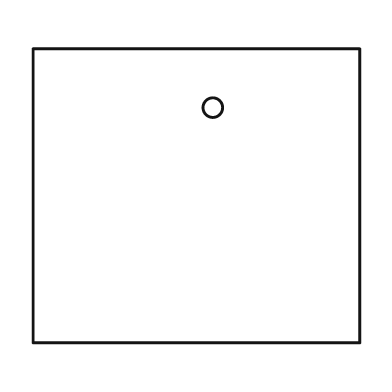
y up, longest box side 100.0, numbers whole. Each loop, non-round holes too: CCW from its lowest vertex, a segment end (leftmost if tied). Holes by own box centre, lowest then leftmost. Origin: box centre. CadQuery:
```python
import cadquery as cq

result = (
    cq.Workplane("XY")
    .moveTo(-50.0, -45.0)
    .lineTo(50.0, -45.0)
    .lineTo(50.0, 45.0)
    .lineTo(-50.0, 45.0)
    .close()
    .moveTo(5.0, 27.0)
    .circle(3.0)
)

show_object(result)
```